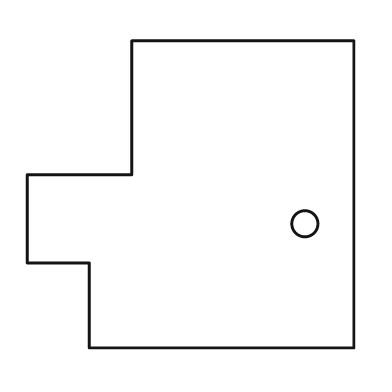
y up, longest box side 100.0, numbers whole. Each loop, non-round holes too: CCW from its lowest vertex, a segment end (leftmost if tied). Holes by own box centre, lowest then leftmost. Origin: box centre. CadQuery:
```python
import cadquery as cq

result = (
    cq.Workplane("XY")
    .moveTo(-31.0, -47.0)
    .lineTo(50.0, -47.0)
    .lineTo(50.0, 47.0)
    .lineTo(-18.0, 47.0)
    .lineTo(-18.0, 6.0)
    .lineTo(-50.0, 6.0)
    .lineTo(-50.0, -21.0)
    .lineTo(-31.0, -21.0)
    .close()
    .moveTo(35.0, -9.0)
    .circle(4.0)
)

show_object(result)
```